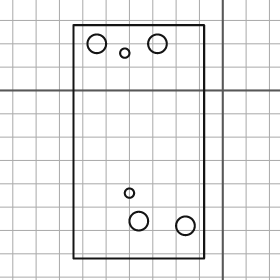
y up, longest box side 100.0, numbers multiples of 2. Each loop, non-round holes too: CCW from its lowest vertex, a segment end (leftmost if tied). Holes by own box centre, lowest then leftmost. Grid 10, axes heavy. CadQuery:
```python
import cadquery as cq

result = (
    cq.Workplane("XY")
    .moveTo(-64.0, -72.0)
    .lineTo(-8.0, -72.0)
    .lineTo(-8.0, 28.0)
    .lineTo(-64.0, 28.0)
    .close()
    .moveTo(-16.0, -58.0)
    .circle(4.0)
    .moveTo(-36.0, -56.0)
    .circle(4.0)
    .moveTo(-40.0, -44.0)
    .circle(2.0)
    .moveTo(-42.0, 16.0)
    .circle(2.0)
    .moveTo(-54.0, 20.0)
    .circle(4.0)
    .moveTo(-28.0, 20.0)
    .circle(4.0)
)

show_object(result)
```